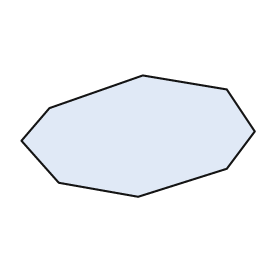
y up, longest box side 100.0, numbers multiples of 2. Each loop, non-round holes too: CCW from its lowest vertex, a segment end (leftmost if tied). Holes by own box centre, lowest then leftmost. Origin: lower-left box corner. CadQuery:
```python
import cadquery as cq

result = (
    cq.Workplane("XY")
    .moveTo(50.0, 0.0)
    .lineTo(88.0, 12.0)
    .lineTo(100.0, 28.0)
    .lineTo(88.0, 46.0)
    .lineTo(52.0, 52.0)
    .lineTo(12.0, 38.0)
    .lineTo(0.0, 24.0)
    .lineTo(16.0, 6.0)
    .close()
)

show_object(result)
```